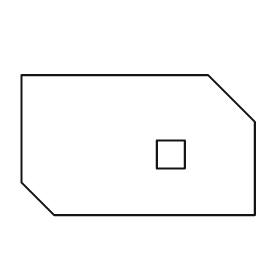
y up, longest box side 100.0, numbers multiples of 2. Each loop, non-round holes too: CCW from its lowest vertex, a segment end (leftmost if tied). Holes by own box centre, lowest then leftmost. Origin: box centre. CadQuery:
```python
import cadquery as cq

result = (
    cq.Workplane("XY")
    .moveTo(-36.0, -30.0)
    .lineTo(50.0, -30.0)
    .lineTo(50.0, 10.0)
    .lineTo(30.0, 30.0)
    .lineTo(-50.0, 30.0)
    .lineTo(-50.0, -16.0)
    .close()
    .moveTo(8.0, -10.0)
    .lineTo(20.0, -10.0)
    .lineTo(20.0, 2.0)
    .lineTo(8.0, 2.0)
    .close()
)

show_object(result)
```